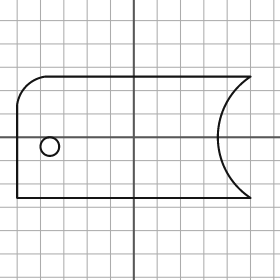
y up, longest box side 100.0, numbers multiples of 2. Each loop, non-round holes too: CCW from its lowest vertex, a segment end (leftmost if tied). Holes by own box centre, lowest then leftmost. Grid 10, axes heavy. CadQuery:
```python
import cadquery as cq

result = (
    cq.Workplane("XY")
    .moveTo(-50.0, -26.0)
    .lineTo(50.0, -26.0)
    .threePointArc((36.0, 0.0), (50.0, 26.0))
    .lineTo(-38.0, 26.0)
    .threePointArc((-46.0, 22.0), (-50.0, 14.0))
    .close()
    .moveTo(-36.0, -4.0)
    .circle(4.0)
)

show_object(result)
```